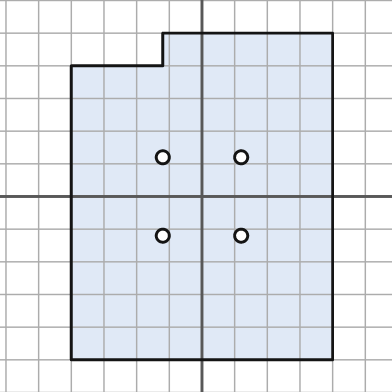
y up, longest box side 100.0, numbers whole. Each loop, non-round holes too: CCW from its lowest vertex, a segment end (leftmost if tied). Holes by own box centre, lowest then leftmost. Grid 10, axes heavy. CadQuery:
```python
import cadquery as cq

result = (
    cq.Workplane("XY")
    .moveTo(-40.0, -50.0)
    .lineTo(40.0, -50.0)
    .lineTo(40.0, 50.0)
    .lineTo(-12.0, 50.0)
    .lineTo(-12.0, 40.0)
    .lineTo(-40.0, 40.0)
    .close()
    .moveTo(-12.0, -12.0)
    .circle(2.0)
    .moveTo(12.0, -12.0)
    .circle(2.0)
    .moveTo(-12.0, 12.0)
    .circle(2.0)
    .moveTo(12.0, 12.0)
    .circle(2.0)
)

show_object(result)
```